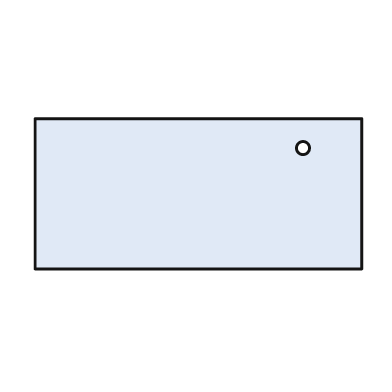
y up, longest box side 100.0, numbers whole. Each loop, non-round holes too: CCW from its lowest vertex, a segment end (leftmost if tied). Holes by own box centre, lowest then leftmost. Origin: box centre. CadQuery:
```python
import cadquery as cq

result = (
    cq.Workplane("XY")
    .moveTo(-50.0, -23.0)
    .lineTo(50.0, -23.0)
    .lineTo(50.0, 23.0)
    .lineTo(-50.0, 23.0)
    .close()
    .moveTo(32.0, 14.0)
    .circle(2.0)
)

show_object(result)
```